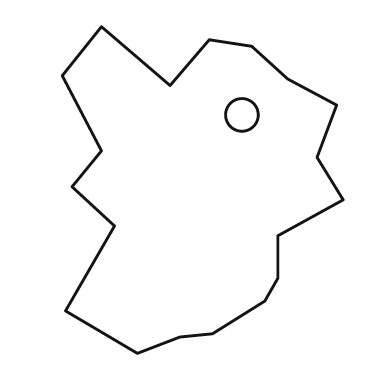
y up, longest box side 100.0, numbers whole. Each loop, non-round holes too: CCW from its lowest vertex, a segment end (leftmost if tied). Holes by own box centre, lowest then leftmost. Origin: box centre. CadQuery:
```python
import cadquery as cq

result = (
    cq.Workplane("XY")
    .moveTo(-20.0, -50.0)
    .lineTo(-7.0, -45.0)
    .lineTo(3.0, -44.0)
    .lineTo(19.0, -34.0)
    .lineTo(23.0, -27.0)
    .lineTo(23.0, -14.0)
    .lineTo(43.0, -3.0)
    .lineTo(35.0, 10.0)
    .lineTo(41.0, 26.0)
    .lineTo(26.0, 34.0)
    .lineTo(15.0, 44.0)
    .lineTo(2.0, 46.0)
    .lineTo(-10.0, 32.0)
    .lineTo(-31.0, 50.0)
    .lineTo(-43.0, 35.0)
    .lineTo(-31.0, 12.0)
    .lineTo(-40.0, 1.0)
    .lineTo(-27.0, -11.0)
    .lineTo(-42.0, -37.0)
    .close()
    .moveTo(12.0, 23.0)
    .circle(5.0)
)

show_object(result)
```